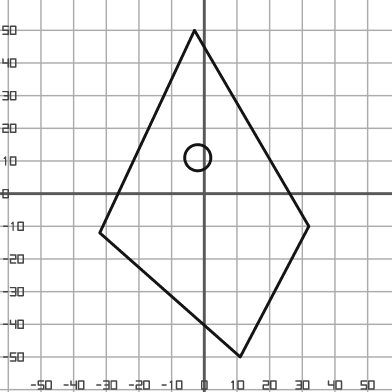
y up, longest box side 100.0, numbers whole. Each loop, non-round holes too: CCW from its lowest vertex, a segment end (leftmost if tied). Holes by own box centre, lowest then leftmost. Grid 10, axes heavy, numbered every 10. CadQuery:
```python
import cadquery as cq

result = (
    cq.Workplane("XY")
    .moveTo(11.0, -50.0)
    .lineTo(32.0, -10.0)
    .lineTo(-3.0, 50.0)
    .lineTo(-32.0, -12.0)
    .close()
    .moveTo(-2.0, 11.0)
    .circle(4.0)
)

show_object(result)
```